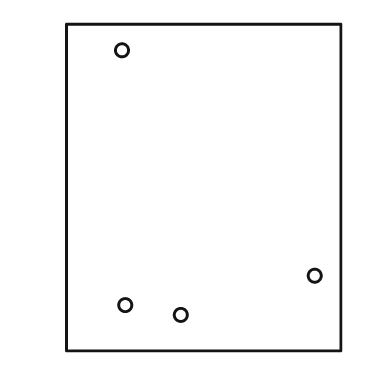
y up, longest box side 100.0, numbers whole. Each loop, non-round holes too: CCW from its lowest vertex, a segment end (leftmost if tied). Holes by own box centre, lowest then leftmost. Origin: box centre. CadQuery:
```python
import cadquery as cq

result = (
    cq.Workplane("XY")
    .moveTo(-42.0, -50.0)
    .lineTo(42.0, -50.0)
    .lineTo(42.0, 50.0)
    .lineTo(-42.0, 50.0)
    .close()
    .moveTo(-7.0, -39.0)
    .circle(2.0)
    .moveTo(-24.0, -36.0)
    .circle(2.0)
    .moveTo(34.0, -27.0)
    .circle(2.0)
    .moveTo(-25.0, 42.0)
    .circle(2.0)
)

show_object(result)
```